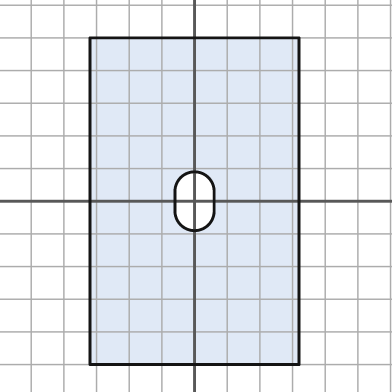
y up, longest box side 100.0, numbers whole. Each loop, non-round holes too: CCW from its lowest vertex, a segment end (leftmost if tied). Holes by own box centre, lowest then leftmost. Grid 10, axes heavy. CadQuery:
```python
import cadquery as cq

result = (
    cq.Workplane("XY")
    .moveTo(-32.0, -50.0)
    .lineTo(32.0, -50.0)
    .lineTo(32.0, 50.0)
    .lineTo(-32.0, 50.0)
    .close()
    .moveTo(-6.0, -3.0)
    .threePointArc((0.0, -9.0), (6.0, -3.0))
    .lineTo(6.0, 3.0)
    .threePointArc((0.0, 9.0), (-6.0, 3.0))
    .close()
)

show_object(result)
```